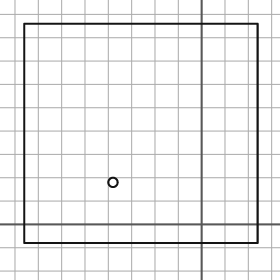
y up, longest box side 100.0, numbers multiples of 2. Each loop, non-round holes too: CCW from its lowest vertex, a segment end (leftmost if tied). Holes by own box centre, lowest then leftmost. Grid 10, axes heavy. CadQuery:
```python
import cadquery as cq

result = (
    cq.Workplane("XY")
    .moveTo(-76.0, -8.0)
    .lineTo(24.0, -8.0)
    .lineTo(24.0, 86.0)
    .lineTo(-76.0, 86.0)
    .close()
    .moveTo(-38.0, 18.0)
    .circle(2.0)
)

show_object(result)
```